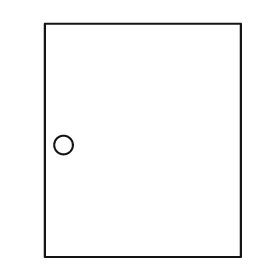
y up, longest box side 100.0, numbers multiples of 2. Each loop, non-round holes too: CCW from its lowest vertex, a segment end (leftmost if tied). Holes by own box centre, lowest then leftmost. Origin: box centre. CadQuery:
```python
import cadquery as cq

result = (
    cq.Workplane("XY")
    .moveTo(-42.0, -50.0)
    .lineTo(42.0, -50.0)
    .lineTo(42.0, 50.0)
    .lineTo(-42.0, 50.0)
    .close()
    .moveTo(-34.0, -2.0)
    .circle(4.0)
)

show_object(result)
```